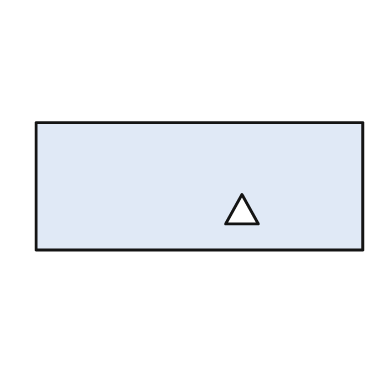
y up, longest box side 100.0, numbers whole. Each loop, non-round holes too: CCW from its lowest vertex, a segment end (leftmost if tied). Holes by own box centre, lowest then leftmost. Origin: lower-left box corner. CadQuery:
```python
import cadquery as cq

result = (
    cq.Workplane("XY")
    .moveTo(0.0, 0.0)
    .lineTo(100.0, 0.0)
    .lineTo(100.0, 39.0)
    .lineTo(0.0, 39.0)
    .close()
    .moveTo(58.0, 8.0)
    .lineTo(68.0, 8.0)
    .lineTo(63.0, 17.0)
    .close()
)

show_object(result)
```